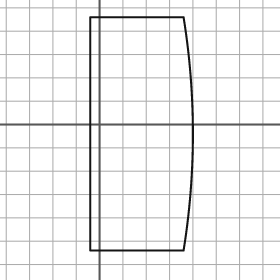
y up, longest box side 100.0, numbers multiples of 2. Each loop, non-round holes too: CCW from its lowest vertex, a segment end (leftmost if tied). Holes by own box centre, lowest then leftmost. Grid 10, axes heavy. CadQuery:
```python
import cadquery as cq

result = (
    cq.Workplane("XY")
    .moveTo(-4.0, -54.0)
    .lineTo(36.0, -54.0)
    .threePointArc((40.0, -4.0), (36.0, 46.0))
    .lineTo(-4.0, 46.0)
    .close()
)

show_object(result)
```